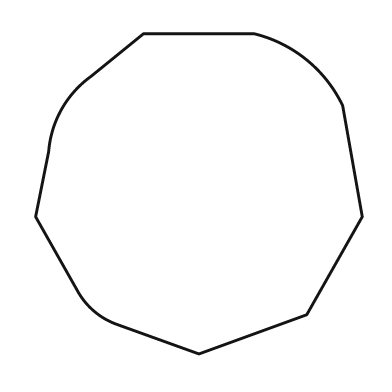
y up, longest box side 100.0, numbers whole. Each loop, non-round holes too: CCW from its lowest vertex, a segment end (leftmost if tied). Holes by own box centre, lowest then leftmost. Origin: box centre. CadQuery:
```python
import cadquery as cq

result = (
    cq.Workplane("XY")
    .moveTo(0.0, -49.0)
    .lineTo(33.0, -37.0)
    .lineTo(50.0, -7.0)
    .lineTo(44.0, 27.0)
    .threePointArc((33.0, 41.0), (17.0, 49.0))
    .lineTo(-17.0, 49.0)
    .lineTo(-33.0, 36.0)
    .threePointArc((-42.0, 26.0), (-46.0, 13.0))
    .lineTo(-50.0, -7.0)
    .lineTo(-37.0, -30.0)
    .threePointArc((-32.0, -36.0), (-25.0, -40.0))
    .close()
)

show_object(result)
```